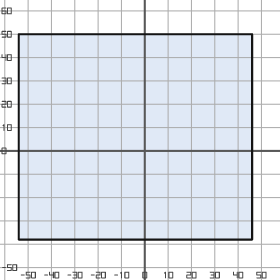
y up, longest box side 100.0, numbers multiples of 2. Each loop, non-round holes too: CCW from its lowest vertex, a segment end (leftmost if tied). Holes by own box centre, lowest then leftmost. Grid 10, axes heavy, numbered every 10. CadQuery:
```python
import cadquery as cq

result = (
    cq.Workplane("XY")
    .moveTo(-54.0, -38.0)
    .lineTo(46.0, -38.0)
    .lineTo(46.0, 50.0)
    .lineTo(-54.0, 50.0)
    .close()
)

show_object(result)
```